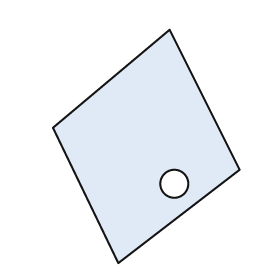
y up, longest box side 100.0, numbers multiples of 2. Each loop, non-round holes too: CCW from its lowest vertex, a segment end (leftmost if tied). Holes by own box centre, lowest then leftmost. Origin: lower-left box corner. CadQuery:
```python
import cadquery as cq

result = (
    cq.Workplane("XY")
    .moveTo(28.0, 0.0)
    .lineTo(80.0, 40.0)
    .lineTo(50.0, 100.0)
    .lineTo(0.0, 58.0)
    .close()
    .moveTo(52.0, 34.0)
    .circle(6.0)
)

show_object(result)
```